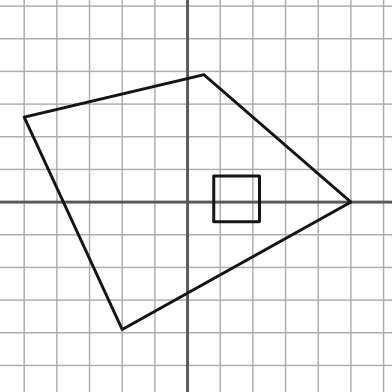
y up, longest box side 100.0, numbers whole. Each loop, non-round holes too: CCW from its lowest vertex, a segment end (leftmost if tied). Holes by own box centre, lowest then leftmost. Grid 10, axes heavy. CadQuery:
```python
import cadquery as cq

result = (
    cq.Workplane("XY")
    .moveTo(-20.0, -39.0)
    .lineTo(50.0, 0.0)
    .lineTo(5.0, 39.0)
    .lineTo(-50.0, 26.0)
    .close()
    .moveTo(8.0, -6.0)
    .lineTo(22.0, -6.0)
    .lineTo(22.0, 8.0)
    .lineTo(8.0, 8.0)
    .close()
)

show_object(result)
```